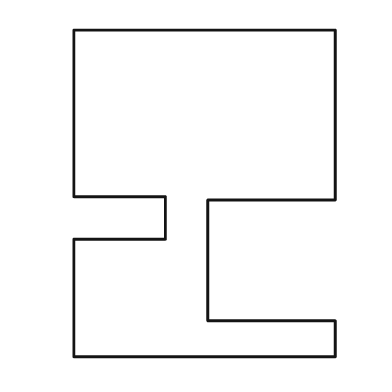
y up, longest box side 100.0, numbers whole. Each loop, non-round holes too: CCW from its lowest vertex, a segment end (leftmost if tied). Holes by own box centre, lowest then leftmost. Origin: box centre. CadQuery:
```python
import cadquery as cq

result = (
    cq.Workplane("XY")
    .moveTo(-40.0, -50.0)
    .lineTo(40.0, -50.0)
    .lineTo(40.0, -39.0)
    .lineTo(1.0, -39.0)
    .lineTo(1.0, -2.0)
    .lineTo(40.0, -2.0)
    .lineTo(40.0, 50.0)
    .lineTo(-40.0, 50.0)
    .lineTo(-40.0, -1.0)
    .lineTo(-12.0, -1.0)
    .lineTo(-12.0, -14.0)
    .lineTo(-40.0, -14.0)
    .close()
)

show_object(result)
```